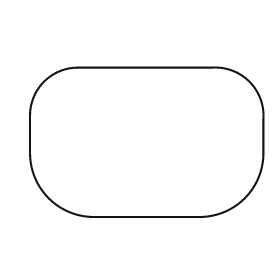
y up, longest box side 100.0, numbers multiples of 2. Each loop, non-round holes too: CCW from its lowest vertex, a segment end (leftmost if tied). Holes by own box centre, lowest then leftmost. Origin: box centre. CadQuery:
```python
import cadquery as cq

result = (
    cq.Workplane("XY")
    .moveTo(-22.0, -32.0)
    .lineTo(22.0, -32.0)
    .threePointArc((42.0, -24.0), (50.0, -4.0))
    .lineTo(50.0, 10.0)
    .threePointArc((44.0, 26.0), (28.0, 32.0))
    .lineTo(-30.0, 32.0)
    .threePointArc((-44.0, 26.0), (-50.0, 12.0))
    .lineTo(-50.0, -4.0)
    .threePointArc((-42.0, -24.0), (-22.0, -32.0))
    .close()
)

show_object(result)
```